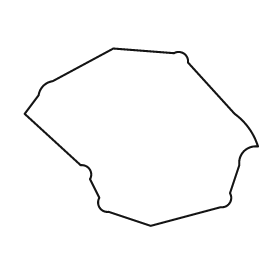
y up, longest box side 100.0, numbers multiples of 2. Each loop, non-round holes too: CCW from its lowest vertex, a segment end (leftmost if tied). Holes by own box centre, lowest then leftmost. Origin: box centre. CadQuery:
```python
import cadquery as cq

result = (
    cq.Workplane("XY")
    .moveTo(4.0, -38.0)
    .lineTo(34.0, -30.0)
    .threePointArc((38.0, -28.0), (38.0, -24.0))
    .lineTo(42.0, -12.0)
    .threePointArc((44.0, -6.0), (50.0, -4.0))
    .threePointArc((46.0, 4.0), (40.0, 10.0))
    .lineTo(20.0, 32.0)
    .threePointArc((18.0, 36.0), (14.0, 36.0))
    .lineTo(-12.0, 38.0)
    .lineTo(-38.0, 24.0)
    .threePointArc((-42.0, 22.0), (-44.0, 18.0))
    .lineTo(-50.0, 10.0)
    .lineTo(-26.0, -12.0)
    .threePointArc((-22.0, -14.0), (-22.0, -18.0))
    .lineTo(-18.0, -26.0)
    .threePointArc((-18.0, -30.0), (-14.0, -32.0))
    .close()
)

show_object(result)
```